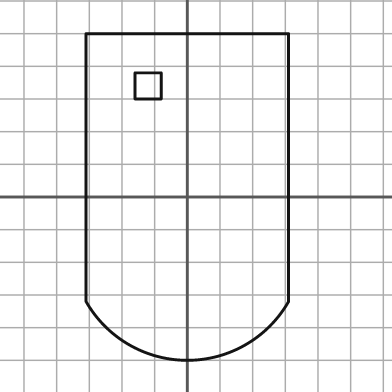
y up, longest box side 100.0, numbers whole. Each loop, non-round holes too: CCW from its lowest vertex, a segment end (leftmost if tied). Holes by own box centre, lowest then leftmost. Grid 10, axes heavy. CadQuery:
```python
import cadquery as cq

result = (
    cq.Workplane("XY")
    .moveTo(-31.0, -32.0)
    .threePointArc((0.0, -50.0), (31.0, -32.0))
    .lineTo(31.0, 50.0)
    .lineTo(-31.0, 50.0)
    .close()
    .moveTo(-16.0, 30.0)
    .lineTo(-8.0, 30.0)
    .lineTo(-8.0, 38.0)
    .lineTo(-16.0, 38.0)
    .close()
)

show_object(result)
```